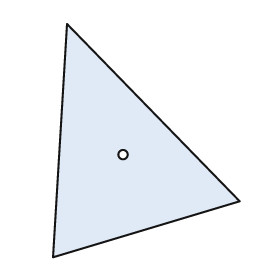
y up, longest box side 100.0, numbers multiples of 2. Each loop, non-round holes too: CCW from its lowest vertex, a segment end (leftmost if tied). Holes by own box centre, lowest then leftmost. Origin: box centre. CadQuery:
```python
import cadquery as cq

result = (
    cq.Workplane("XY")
    .moveTo(-40.0, -50.0)
    .lineTo(40.0, -26.0)
    .lineTo(-34.0, 50.0)
    .close()
    .moveTo(-10.0, -6.0)
    .circle(2.0)
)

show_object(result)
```